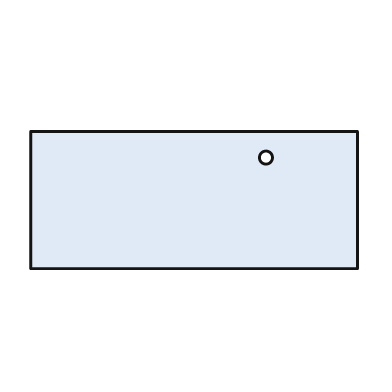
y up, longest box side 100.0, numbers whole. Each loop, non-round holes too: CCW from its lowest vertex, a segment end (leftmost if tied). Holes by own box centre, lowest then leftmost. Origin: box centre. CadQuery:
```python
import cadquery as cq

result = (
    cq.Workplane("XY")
    .moveTo(-50.0, -21.0)
    .lineTo(50.0, -21.0)
    .lineTo(50.0, 21.0)
    .lineTo(-50.0, 21.0)
    .close()
    .moveTo(22.0, 13.0)
    .circle(2.0)
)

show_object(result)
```